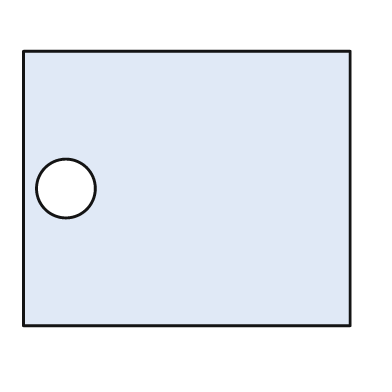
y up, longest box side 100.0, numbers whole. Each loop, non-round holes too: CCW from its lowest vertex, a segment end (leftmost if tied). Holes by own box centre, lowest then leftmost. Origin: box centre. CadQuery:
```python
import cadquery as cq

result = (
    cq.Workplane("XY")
    .moveTo(-50.0, -42.0)
    .lineTo(50.0, -42.0)
    .lineTo(50.0, 42.0)
    .lineTo(-50.0, 42.0)
    .close()
    .moveTo(-37.0, 0.0)
    .circle(9.0)
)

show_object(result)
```